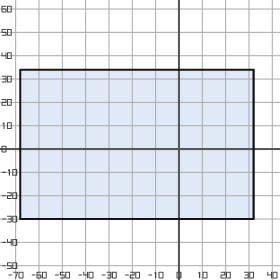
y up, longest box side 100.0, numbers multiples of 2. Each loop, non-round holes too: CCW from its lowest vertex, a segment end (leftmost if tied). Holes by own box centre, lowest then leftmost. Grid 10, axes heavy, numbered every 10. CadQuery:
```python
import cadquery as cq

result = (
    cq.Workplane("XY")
    .moveTo(-68.0, -30.0)
    .lineTo(32.0, -30.0)
    .lineTo(32.0, 34.0)
    .lineTo(-68.0, 34.0)
    .close()
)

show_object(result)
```